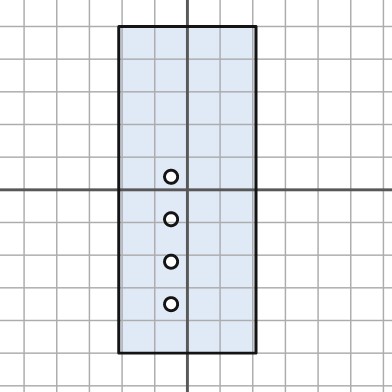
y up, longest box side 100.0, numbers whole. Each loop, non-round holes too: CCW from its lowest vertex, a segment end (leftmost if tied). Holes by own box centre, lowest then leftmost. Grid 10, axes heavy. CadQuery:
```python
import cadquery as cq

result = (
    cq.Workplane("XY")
    .moveTo(-21.0, -50.0)
    .lineTo(21.0, -50.0)
    .lineTo(21.0, 50.0)
    .lineTo(-21.0, 50.0)
    .close()
    .moveTo(-5.0, -35.0)
    .circle(2.0)
    .moveTo(-5.0, -22.0)
    .circle(2.0)
    .moveTo(-5.0, -9.0)
    .circle(2.0)
    .moveTo(-5.0, 4.0)
    .circle(2.0)
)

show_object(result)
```